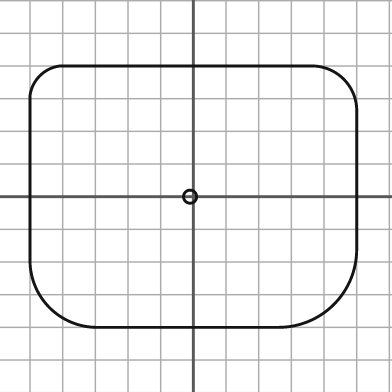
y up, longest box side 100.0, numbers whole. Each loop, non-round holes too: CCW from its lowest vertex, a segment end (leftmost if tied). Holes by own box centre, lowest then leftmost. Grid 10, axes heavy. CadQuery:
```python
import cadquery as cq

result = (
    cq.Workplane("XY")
    .moveTo(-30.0, -40.0)
    .lineTo(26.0, -40.0)
    .threePointArc((43.0, -33.0), (50.0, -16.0))
    .lineTo(50.0, 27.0)
    .threePointArc((46.0, 36.0), (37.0, 40.0))
    .lineTo(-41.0, 40.0)
    .threePointArc((-47.0, 37.0), (-50.0, 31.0))
    .lineTo(-50.0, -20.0)
    .threePointArc((-44.0, -34.0), (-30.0, -40.0))
    .close()
    .moveTo(-1.0, 0.0)
    .circle(2.0)
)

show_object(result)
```